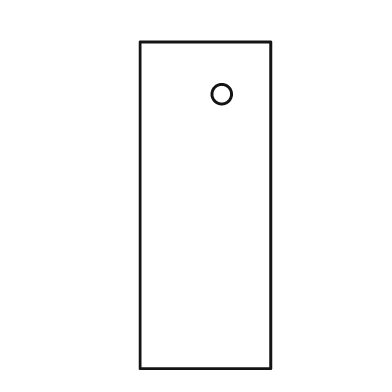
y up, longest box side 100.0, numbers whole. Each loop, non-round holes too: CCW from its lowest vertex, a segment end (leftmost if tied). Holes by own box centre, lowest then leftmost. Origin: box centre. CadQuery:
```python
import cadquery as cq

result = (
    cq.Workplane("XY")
    .moveTo(-20.0, -50.0)
    .lineTo(20.0, -50.0)
    .lineTo(20.0, 50.0)
    .lineTo(-20.0, 50.0)
    .close()
    .moveTo(5.0, 34.0)
    .circle(3.0)
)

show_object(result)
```